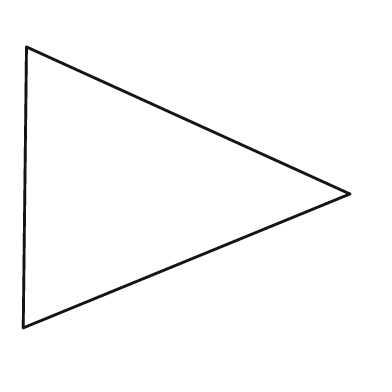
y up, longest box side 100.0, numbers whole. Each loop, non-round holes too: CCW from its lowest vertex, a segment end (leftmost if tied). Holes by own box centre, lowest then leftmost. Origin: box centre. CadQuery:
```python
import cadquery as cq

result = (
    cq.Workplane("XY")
    .moveTo(-50.0, -43.0)
    .lineTo(50.0, -2.0)
    .lineTo(-49.0, 43.0)
    .close()
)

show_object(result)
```